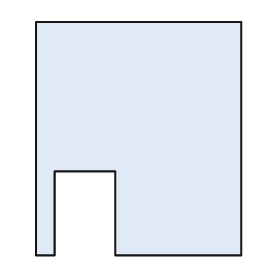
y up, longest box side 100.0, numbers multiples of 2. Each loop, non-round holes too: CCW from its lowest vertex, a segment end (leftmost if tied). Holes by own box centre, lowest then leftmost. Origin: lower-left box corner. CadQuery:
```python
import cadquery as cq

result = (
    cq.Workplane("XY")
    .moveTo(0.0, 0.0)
    .lineTo(8.0, 0.0)
    .lineTo(8.0, 36.0)
    .lineTo(34.0, 36.0)
    .lineTo(34.0, 0.0)
    .lineTo(88.0, 0.0)
    .lineTo(88.0, 100.0)
    .lineTo(0.0, 100.0)
    .close()
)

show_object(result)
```